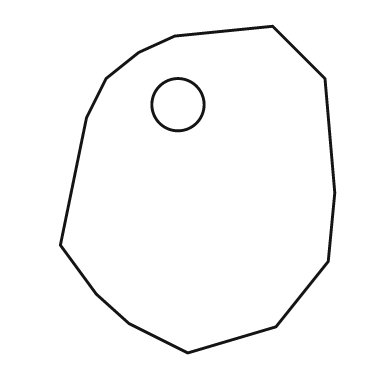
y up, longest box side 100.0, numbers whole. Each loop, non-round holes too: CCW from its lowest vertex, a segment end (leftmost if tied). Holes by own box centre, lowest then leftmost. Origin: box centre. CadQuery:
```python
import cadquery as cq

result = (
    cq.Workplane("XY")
    .moveTo(-3.0, -50.0)
    .lineTo(24.0, -42.0)
    .lineTo(40.0, -22.0)
    .lineTo(42.0, -1.0)
    .lineTo(39.0, 34.0)
    .lineTo(23.0, 50.0)
    .lineTo(-7.0, 47.0)
    .lineTo(-18.0, 42.0)
    .lineTo(-28.0, 34.0)
    .lineTo(-34.0, 22.0)
    .lineTo(-42.0, -17.0)
    .lineTo(-31.0, -32.0)
    .lineTo(-21.0, -41.0)
    .close()
    .moveTo(-6.0, 26.0)
    .circle(8.0)
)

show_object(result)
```